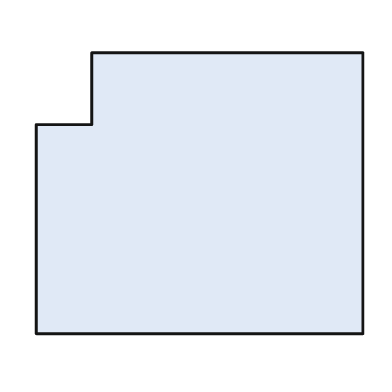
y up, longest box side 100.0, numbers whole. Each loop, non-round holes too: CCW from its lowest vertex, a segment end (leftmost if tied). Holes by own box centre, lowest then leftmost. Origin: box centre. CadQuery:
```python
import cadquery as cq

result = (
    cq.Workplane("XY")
    .moveTo(-50.0, -43.0)
    .lineTo(50.0, -43.0)
    .lineTo(50.0, 43.0)
    .lineTo(-33.0, 43.0)
    .lineTo(-33.0, 21.0)
    .lineTo(-50.0, 21.0)
    .close()
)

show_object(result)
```